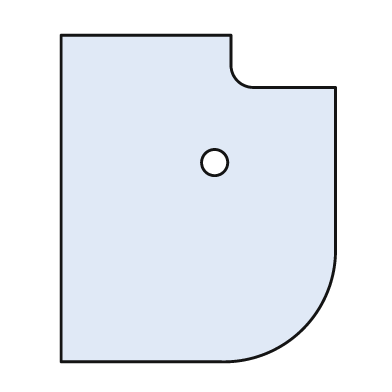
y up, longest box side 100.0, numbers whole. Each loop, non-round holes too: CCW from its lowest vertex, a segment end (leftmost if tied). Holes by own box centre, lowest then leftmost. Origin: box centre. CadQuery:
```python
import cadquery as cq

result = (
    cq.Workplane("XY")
    .moveTo(-42.0, -50.0)
    .lineTo(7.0, -50.0)
    .threePointArc((32.0, -40.0), (42.0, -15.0))
    .lineTo(42.0, 34.0)
    .lineTo(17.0, 34.0)
    .threePointArc((12.0, 36.0), (10.0, 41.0))
    .lineTo(10.0, 50.0)
    .lineTo(-42.0, 50.0)
    .close()
    .moveTo(5.0, 11.0)
    .circle(4.0)
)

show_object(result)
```